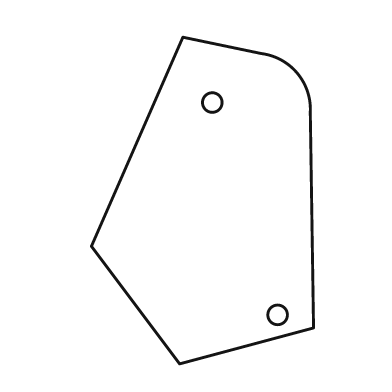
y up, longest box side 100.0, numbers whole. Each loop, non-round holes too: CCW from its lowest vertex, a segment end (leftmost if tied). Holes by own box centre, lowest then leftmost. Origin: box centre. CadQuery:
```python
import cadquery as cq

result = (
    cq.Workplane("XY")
    .moveTo(-7.0, -50.0)
    .lineTo(34.0, -39.0)
    .lineTo(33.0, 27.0)
    .threePointArc((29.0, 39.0), (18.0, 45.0))
    .lineTo(-6.0, 50.0)
    .lineTo(-34.0, -14.0)
    .close()
    .moveTo(23.0, -35.0)
    .circle(3.0)
    .moveTo(3.0, 30.0)
    .circle(3.0)
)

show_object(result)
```